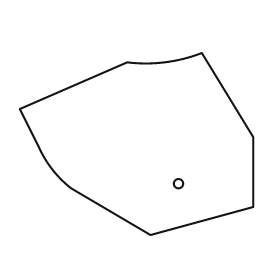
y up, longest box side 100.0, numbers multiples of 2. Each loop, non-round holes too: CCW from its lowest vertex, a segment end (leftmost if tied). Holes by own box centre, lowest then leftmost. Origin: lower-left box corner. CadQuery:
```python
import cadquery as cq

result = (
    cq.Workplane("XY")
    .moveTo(56.0, 0.0)
    .lineTo(100.0, 12.0)
    .lineTo(100.0, 42.0)
    .lineTo(78.0, 78.0)
    .threePointArc((62.0, 74.0), (46.0, 74.0))
    .lineTo(0.0, 54.0)
    .lineTo(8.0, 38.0)
    .threePointArc((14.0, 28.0), (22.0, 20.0))
    .close()
    .moveTo(68.0, 22.0)
    .circle(2.0)
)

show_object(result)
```